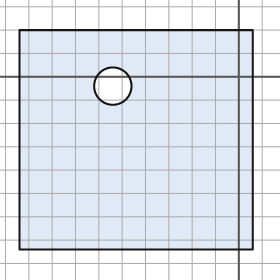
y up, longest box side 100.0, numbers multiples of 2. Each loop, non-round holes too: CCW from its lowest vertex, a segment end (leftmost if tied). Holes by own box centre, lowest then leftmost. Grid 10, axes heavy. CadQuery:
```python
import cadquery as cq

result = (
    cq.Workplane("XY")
    .moveTo(-94.0, -74.0)
    .lineTo(6.0, -74.0)
    .lineTo(6.0, 20.0)
    .lineTo(-94.0, 20.0)
    .close()
    .moveTo(-54.0, -4.0)
    .circle(8.0)
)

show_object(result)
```